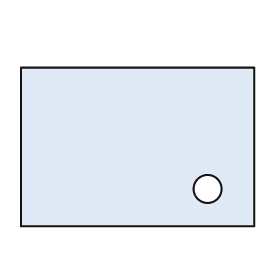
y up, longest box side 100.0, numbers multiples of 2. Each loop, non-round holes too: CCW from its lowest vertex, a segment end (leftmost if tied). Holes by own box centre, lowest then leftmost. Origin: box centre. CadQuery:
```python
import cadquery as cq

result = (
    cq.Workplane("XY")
    .moveTo(-50.0, -34.0)
    .lineTo(50.0, -34.0)
    .lineTo(50.0, 34.0)
    .lineTo(-50.0, 34.0)
    .close()
    .moveTo(30.0, -18.0)
    .circle(6.0)
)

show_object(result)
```